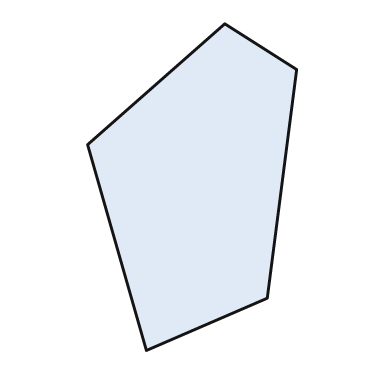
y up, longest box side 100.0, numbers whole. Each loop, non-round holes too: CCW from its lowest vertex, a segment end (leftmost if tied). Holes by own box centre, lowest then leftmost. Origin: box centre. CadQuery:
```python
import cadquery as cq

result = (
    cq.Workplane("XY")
    .moveTo(-14.0, -50.0)
    .lineTo(23.0, -34.0)
    .lineTo(32.0, 36.0)
    .lineTo(10.0, 50.0)
    .lineTo(-32.0, 13.0)
    .close()
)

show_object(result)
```